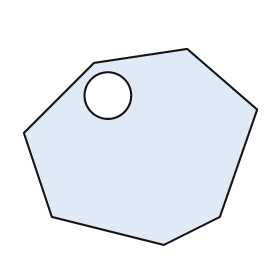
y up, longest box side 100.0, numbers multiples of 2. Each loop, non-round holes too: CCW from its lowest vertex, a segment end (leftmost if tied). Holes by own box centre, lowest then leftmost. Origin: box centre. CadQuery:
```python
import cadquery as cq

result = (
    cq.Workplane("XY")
    .moveTo(10.0, -42.0)
    .lineTo(34.0, -30.0)
    .lineTo(50.0, 16.0)
    .lineTo(20.0, 42.0)
    .lineTo(-20.0, 36.0)
    .lineTo(-50.0, 6.0)
    .lineTo(-38.0, -30.0)
    .close()
    .moveTo(-14.0, 22.0)
    .circle(10.0)
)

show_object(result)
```